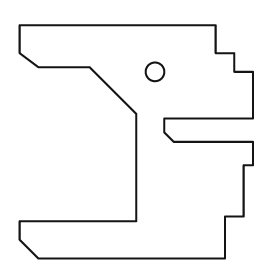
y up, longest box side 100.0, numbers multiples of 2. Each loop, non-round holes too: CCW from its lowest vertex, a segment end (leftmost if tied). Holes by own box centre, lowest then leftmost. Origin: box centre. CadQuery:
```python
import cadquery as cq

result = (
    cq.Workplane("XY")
    .moveTo(-42.0, -50.0)
    .lineTo(38.0, -50.0)
    .lineTo(38.0, -32.0)
    .lineTo(46.0, -32.0)
    .lineTo(46.0, -10.0)
    .lineTo(50.0, -10.0)
    .lineTo(50.0, 0.0)
    .lineTo(16.0, 0.0)
    .lineTo(12.0, 4.0)
    .lineTo(12.0, 10.0)
    .lineTo(50.0, 10.0)
    .lineTo(50.0, 30.0)
    .lineTo(42.0, 30.0)
    .lineTo(42.0, 38.0)
    .lineTo(34.0, 38.0)
    .lineTo(34.0, 50.0)
    .lineTo(-50.0, 50.0)
    .lineTo(-50.0, 38.0)
    .lineTo(-42.0, 32.0)
    .lineTo(-20.0, 32.0)
    .lineTo(0.0, 12.0)
    .lineTo(0.0, -34.0)
    .lineTo(-50.0, -34.0)
    .lineTo(-50.0, -42.0)
    .close()
    .moveTo(8.0, 30.0)
    .circle(4.0)
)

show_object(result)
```